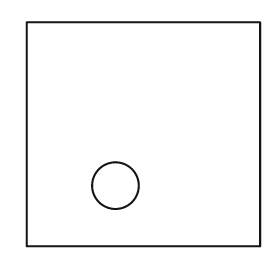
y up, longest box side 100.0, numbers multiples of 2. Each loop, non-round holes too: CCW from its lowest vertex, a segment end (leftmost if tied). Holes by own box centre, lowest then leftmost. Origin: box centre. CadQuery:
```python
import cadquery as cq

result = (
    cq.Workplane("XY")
    .moveTo(-50.0, -48.0)
    .lineTo(50.0, -48.0)
    .lineTo(50.0, 48.0)
    .lineTo(-50.0, 48.0)
    .close()
    .moveTo(-12.0, -22.0)
    .circle(10.0)
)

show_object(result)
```